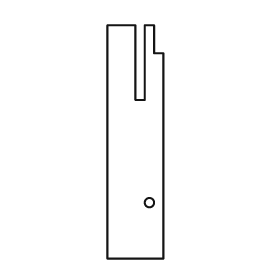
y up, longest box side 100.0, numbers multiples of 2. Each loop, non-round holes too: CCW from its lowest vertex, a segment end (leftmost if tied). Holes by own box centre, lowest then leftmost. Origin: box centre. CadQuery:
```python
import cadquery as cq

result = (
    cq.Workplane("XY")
    .moveTo(-12.0, -50.0)
    .lineTo(12.0, -50.0)
    .lineTo(12.0, 38.0)
    .lineTo(8.0, 38.0)
    .lineTo(8.0, 50.0)
    .lineTo(4.0, 50.0)
    .lineTo(4.0, 18.0)
    .lineTo(0.0, 18.0)
    .lineTo(0.0, 50.0)
    .lineTo(-12.0, 50.0)
    .close()
    .moveTo(6.0, -26.0)
    .circle(2.0)
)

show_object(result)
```